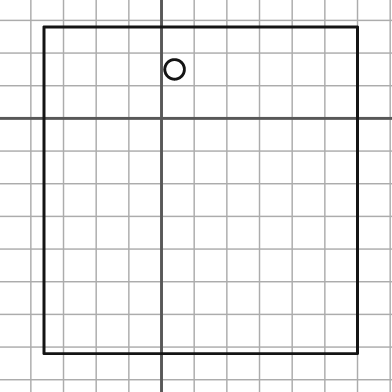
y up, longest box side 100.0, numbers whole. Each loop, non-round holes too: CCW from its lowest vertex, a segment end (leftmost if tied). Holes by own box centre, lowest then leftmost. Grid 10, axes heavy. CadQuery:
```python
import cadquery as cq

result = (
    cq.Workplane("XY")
    .moveTo(-36.0, -72.0)
    .lineTo(60.0, -72.0)
    .lineTo(60.0, 28.0)
    .lineTo(-36.0, 28.0)
    .close()
    .moveTo(4.0, 15.0)
    .circle(3.0)
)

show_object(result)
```